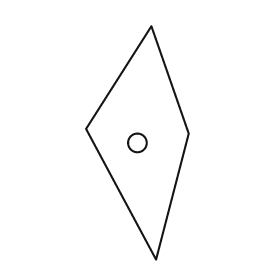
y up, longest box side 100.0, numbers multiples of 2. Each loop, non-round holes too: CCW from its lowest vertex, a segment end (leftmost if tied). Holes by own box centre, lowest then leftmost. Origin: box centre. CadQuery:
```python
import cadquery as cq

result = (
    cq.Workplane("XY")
    .moveTo(8.0, -50.0)
    .lineTo(22.0, 4.0)
    .lineTo(6.0, 50.0)
    .lineTo(-22.0, 6.0)
    .close()
    .moveTo(0.0, 0.0)
    .circle(4.0)
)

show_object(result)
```